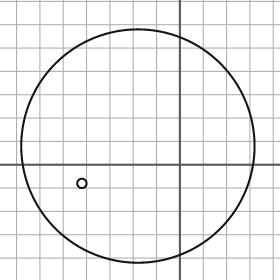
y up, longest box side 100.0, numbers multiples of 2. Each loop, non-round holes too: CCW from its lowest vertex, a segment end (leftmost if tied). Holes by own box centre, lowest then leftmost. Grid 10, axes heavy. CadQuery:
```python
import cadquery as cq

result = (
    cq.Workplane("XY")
    .moveTo(-18.0, 8.0)
    .circle(50.0)
    .moveTo(-42.0, -8.0)
    .circle(2.0)
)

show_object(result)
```